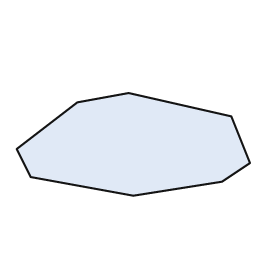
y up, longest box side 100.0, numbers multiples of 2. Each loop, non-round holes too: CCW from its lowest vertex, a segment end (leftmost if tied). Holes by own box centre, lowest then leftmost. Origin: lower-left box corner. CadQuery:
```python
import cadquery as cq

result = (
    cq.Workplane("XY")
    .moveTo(50.0, 0.0)
    .lineTo(88.0, 6.0)
    .lineTo(100.0, 14.0)
    .lineTo(92.0, 34.0)
    .lineTo(48.0, 44.0)
    .lineTo(26.0, 40.0)
    .lineTo(0.0, 20.0)
    .lineTo(6.0, 8.0)
    .close()
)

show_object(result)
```